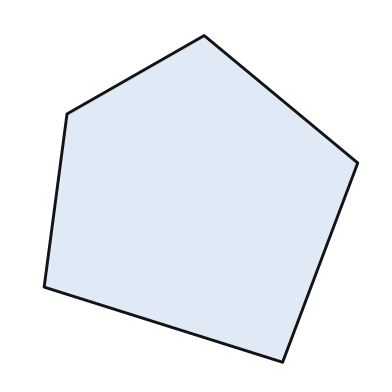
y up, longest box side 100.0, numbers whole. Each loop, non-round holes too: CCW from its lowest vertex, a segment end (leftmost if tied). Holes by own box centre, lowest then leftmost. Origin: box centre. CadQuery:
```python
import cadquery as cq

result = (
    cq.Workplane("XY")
    .moveTo(25.0, -50.0)
    .lineTo(48.0, 11.0)
    .lineTo(1.0, 50.0)
    .lineTo(-41.0, 26.0)
    .lineTo(-48.0, -27.0)
    .close()
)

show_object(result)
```